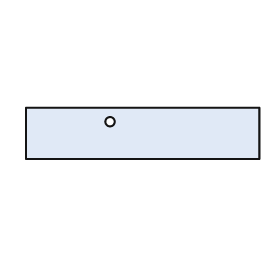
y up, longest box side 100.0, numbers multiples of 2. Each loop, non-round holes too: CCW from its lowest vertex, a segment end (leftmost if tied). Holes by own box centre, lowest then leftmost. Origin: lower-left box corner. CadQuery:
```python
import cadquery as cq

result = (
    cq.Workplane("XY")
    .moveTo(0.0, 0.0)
    .lineTo(100.0, 0.0)
    .lineTo(100.0, 22.0)
    .lineTo(0.0, 22.0)
    .close()
    .moveTo(36.0, 16.0)
    .circle(2.0)
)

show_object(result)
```